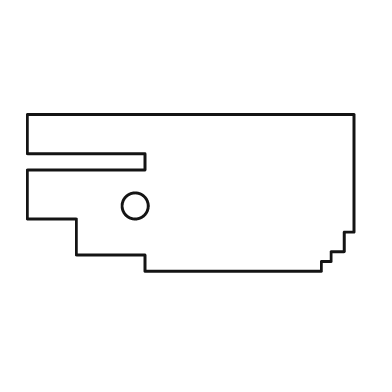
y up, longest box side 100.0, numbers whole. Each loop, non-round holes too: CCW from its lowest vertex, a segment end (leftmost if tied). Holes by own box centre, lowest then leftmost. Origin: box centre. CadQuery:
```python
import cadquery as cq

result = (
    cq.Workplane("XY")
    .moveTo(-14.0, -24.0)
    .lineTo(40.0, -24.0)
    .lineTo(40.0, -21.0)
    .lineTo(43.0, -21.0)
    .lineTo(43.0, -18.0)
    .lineTo(47.0, -18.0)
    .lineTo(47.0, -12.0)
    .lineTo(50.0, -12.0)
    .lineTo(50.0, 24.0)
    .lineTo(-50.0, 24.0)
    .lineTo(-50.0, 12.0)
    .lineTo(-14.0, 12.0)
    .lineTo(-14.0, 7.0)
    .lineTo(-50.0, 7.0)
    .lineTo(-50.0, -8.0)
    .lineTo(-35.0, -8.0)
    .lineTo(-35.0, -19.0)
    .lineTo(-14.0, -19.0)
    .close()
    .moveTo(-17.0, -4.0)
    .circle(4.0)
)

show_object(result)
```